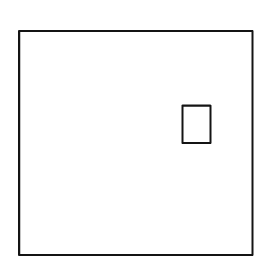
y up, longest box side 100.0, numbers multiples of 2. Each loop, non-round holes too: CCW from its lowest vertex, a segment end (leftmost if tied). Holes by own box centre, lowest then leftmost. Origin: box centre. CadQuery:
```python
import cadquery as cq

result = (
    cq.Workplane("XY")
    .moveTo(-50.0, -48.0)
    .lineTo(50.0, -48.0)
    .lineTo(50.0, 48.0)
    .lineTo(-50.0, 48.0)
    .close()
    .moveTo(20.0, 0.0)
    .lineTo(32.0, 0.0)
    .lineTo(32.0, 16.0)
    .lineTo(20.0, 16.0)
    .close()
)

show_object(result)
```